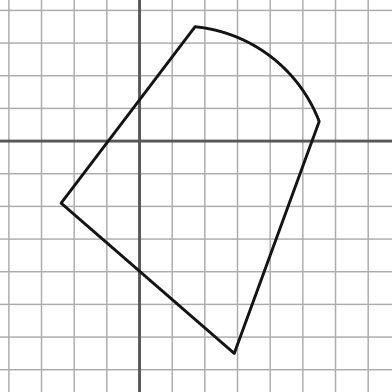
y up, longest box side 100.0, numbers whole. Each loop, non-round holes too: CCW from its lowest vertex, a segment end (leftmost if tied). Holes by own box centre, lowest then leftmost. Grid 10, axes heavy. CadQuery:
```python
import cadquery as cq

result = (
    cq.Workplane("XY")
    .moveTo(29.0, -65.0)
    .lineTo(55.0, 6.0)
    .threePointArc((40.0, 26.0), (17.0, 35.0))
    .lineTo(-24.0, -19.0)
    .close()
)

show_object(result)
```